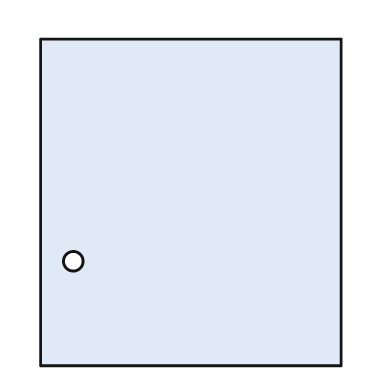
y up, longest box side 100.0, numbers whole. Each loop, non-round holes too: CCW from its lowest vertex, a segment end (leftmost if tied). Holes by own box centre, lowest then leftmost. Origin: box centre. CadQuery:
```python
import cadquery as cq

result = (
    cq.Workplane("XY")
    .moveTo(-46.0, -50.0)
    .lineTo(46.0, -50.0)
    .lineTo(46.0, 50.0)
    .lineTo(-46.0, 50.0)
    .close()
    .moveTo(-36.0, -18.0)
    .circle(3.0)
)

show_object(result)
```